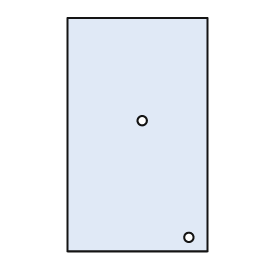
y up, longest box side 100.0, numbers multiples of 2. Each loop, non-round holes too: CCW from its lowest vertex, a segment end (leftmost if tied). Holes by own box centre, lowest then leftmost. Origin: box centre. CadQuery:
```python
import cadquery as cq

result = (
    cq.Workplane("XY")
    .moveTo(-30.0, -50.0)
    .lineTo(30.0, -50.0)
    .lineTo(30.0, 50.0)
    .lineTo(-30.0, 50.0)
    .close()
    .moveTo(22.0, -44.0)
    .circle(2.0)
    .moveTo(2.0, 6.0)
    .circle(2.0)
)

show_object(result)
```